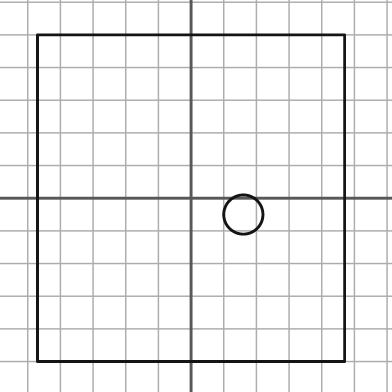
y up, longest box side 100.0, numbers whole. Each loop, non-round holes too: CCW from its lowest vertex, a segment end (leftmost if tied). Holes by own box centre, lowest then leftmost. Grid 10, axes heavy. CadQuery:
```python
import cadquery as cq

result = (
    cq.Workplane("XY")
    .moveTo(-47.0, -50.0)
    .lineTo(47.0, -50.0)
    .lineTo(47.0, 50.0)
    .lineTo(-47.0, 50.0)
    .close()
    .moveTo(16.0, -5.0)
    .circle(6.0)
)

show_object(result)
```